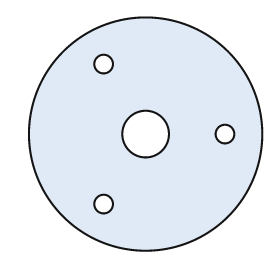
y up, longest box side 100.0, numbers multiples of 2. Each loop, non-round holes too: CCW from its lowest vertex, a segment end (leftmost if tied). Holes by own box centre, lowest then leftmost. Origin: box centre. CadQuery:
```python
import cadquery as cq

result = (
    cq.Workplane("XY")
    .moveTo(0.0, 0.0)
    .circle(50.0)
    .moveTo(-18.0, -30.0)
    .circle(4.0)
    .moveTo(0.0, 0.0)
    .circle(10.0)
    .moveTo(34.0, 0.0)
    .circle(4.0)
    .moveTo(-18.0, 30.0)
    .circle(4.0)
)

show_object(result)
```